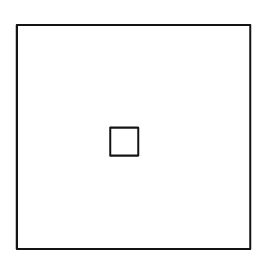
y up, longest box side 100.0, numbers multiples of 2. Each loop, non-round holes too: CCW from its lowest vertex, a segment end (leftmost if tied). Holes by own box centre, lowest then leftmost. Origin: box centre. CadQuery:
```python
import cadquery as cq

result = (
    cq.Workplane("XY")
    .moveTo(-50.0, -48.0)
    .lineTo(50.0, -48.0)
    .lineTo(50.0, 48.0)
    .lineTo(-50.0, 48.0)
    .close()
    .moveTo(-10.0, -8.0)
    .lineTo(2.0, -8.0)
    .lineTo(2.0, 4.0)
    .lineTo(-10.0, 4.0)
    .close()
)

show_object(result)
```